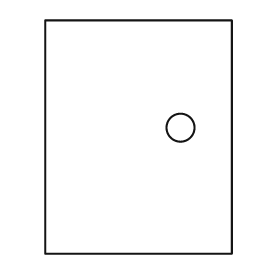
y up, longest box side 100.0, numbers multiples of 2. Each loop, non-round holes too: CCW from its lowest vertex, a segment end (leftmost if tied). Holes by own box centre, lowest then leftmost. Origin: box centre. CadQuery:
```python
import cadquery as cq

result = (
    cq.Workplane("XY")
    .moveTo(-40.0, -50.0)
    .lineTo(40.0, -50.0)
    .lineTo(40.0, 50.0)
    .lineTo(-40.0, 50.0)
    .close()
    .moveTo(18.0, 4.0)
    .circle(6.0)
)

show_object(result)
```